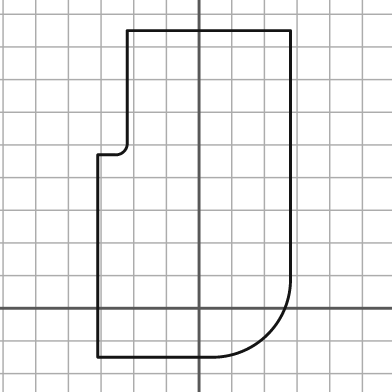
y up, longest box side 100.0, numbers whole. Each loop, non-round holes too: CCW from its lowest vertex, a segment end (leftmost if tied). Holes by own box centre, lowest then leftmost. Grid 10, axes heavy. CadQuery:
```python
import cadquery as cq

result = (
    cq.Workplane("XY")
    .moveTo(-31.0, -15.0)
    .lineTo(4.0, -15.0)
    .threePointArc((21.0, -8.0), (28.0, 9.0))
    .lineTo(28.0, 85.0)
    .lineTo(-22.0, 85.0)
    .lineTo(-22.0, 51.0)
    .threePointArc((-23.0, 48.0), (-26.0, 47.0))
    .lineTo(-31.0, 47.0)
    .close()
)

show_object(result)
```